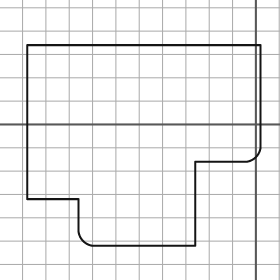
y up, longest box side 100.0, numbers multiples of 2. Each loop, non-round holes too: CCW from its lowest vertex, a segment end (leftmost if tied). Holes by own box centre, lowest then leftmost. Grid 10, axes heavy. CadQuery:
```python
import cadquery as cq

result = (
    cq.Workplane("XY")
    .moveTo(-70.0, -52.0)
    .lineTo(-26.0, -52.0)
    .lineTo(-26.0, -16.0)
    .lineTo(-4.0, -16.0)
    .threePointArc((0.0, -14.0), (2.0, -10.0))
    .lineTo(2.0, 34.0)
    .lineTo(-98.0, 34.0)
    .lineTo(-98.0, -32.0)
    .lineTo(-76.0, -32.0)
    .lineTo(-76.0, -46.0)
    .threePointArc((-74.0, -50.0), (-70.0, -52.0))
    .close()
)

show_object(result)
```